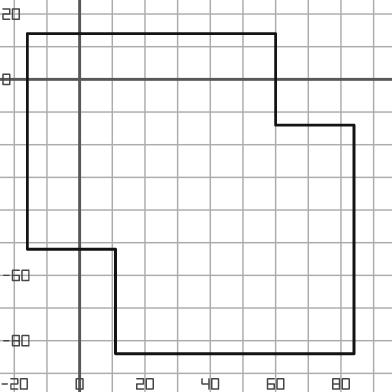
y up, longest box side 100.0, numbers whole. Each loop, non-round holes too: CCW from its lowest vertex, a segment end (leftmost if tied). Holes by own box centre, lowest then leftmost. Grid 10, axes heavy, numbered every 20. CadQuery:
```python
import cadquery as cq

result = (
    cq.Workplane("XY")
    .moveTo(11.0, -84.0)
    .lineTo(84.0, -84.0)
    .lineTo(84.0, -14.0)
    .lineTo(60.0, -14.0)
    .lineTo(60.0, 14.0)
    .lineTo(-16.0, 14.0)
    .lineTo(-16.0, -52.0)
    .lineTo(11.0, -52.0)
    .close()
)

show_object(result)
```